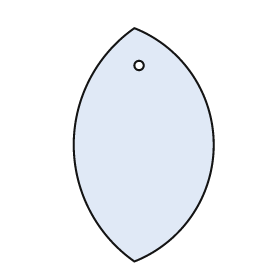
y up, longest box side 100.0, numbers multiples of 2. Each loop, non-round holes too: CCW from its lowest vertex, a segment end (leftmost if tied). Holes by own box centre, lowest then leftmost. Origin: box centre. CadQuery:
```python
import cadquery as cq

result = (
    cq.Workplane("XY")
    .moveTo(-4.0, -50.0)
    .threePointArc((30.0, 0.0), (-4.0, 50.0))
    .threePointArc((-30.0, 0.0), (-4.0, -50.0))
    .close()
    .moveTo(-2.0, 34.0)
    .circle(2.0)
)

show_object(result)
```